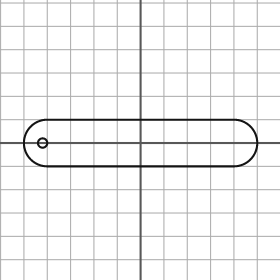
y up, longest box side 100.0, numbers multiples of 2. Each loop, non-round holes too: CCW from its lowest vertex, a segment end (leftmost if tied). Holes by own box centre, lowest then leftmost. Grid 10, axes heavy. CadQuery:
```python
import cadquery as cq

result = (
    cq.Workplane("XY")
    .moveTo(-40.0, -10.0)
    .lineTo(40.0, -10.0)
    .threePointArc((50.0, 0.0), (40.0, 10.0))
    .lineTo(-40.0, 10.0)
    .threePointArc((-50.0, 0.0), (-40.0, -10.0))
    .close()
    .moveTo(-42.0, 0.0)
    .circle(2.0)
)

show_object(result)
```